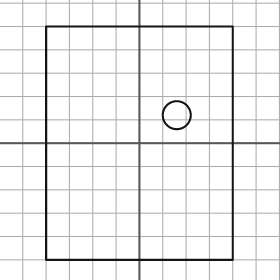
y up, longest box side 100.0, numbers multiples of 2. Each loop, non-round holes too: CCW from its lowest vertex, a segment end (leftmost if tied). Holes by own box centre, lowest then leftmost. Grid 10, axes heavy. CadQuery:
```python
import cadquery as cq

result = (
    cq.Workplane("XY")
    .moveTo(-40.0, -50.0)
    .lineTo(40.0, -50.0)
    .lineTo(40.0, 50.0)
    .lineTo(-40.0, 50.0)
    .close()
    .moveTo(16.0, 12.0)
    .circle(6.0)
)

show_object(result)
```